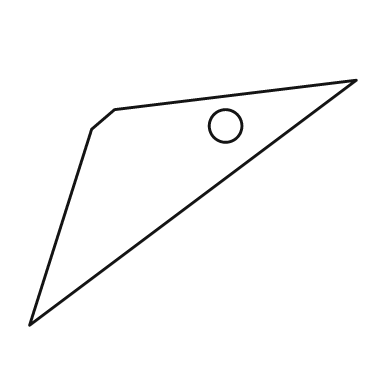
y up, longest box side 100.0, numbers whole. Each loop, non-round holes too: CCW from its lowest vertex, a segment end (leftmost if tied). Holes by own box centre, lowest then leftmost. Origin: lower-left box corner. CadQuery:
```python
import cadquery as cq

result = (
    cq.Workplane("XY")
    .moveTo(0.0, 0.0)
    .lineTo(100.0, 75.0)
    .lineTo(26.0, 66.0)
    .lineTo(19.0, 60.0)
    .close()
    .moveTo(60.0, 61.0)
    .circle(5.0)
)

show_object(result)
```